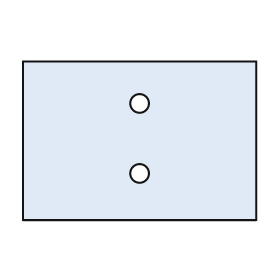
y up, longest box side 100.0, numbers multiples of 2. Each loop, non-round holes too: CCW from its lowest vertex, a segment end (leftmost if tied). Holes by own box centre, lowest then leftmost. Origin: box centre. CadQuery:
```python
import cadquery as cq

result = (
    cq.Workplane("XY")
    .moveTo(-50.0, -34.0)
    .lineTo(50.0, -34.0)
    .lineTo(50.0, 34.0)
    .lineTo(-50.0, 34.0)
    .close()
    .moveTo(0.0, -14.0)
    .circle(4.0)
    .moveTo(0.0, 16.0)
    .circle(4.0)
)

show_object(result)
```